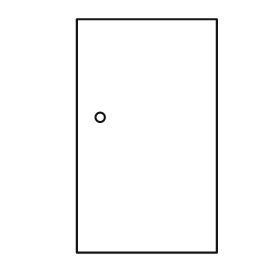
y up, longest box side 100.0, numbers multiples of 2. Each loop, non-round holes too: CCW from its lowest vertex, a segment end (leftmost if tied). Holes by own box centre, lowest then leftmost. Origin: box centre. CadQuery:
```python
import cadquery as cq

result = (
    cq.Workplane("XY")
    .moveTo(-30.0, -50.0)
    .lineTo(30.0, -50.0)
    .lineTo(30.0, 50.0)
    .lineTo(-30.0, 50.0)
    .close()
    .moveTo(-20.0, 8.0)
    .circle(2.0)
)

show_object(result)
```